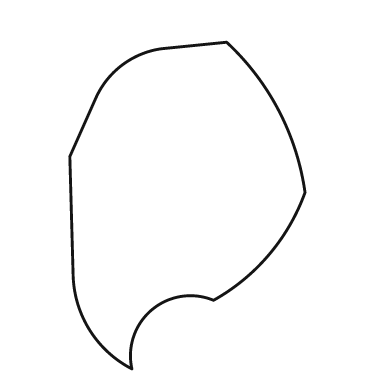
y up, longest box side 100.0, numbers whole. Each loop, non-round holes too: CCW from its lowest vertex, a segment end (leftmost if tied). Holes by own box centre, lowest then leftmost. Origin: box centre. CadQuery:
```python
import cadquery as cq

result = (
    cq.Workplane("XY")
    .moveTo(-17.0, -50.0)
    .threePointArc((-11.0, -32.0), (8.0, -29.0))
    .threePointArc((25.0, -15.0), (36.0, 4.0))
    .threePointArc((28.0, 29.0), (12.0, 50.0))
    .lineTo(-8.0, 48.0)
    .threePointArc((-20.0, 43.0), (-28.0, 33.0))
    .lineTo(-36.0, 15.0)
    .lineTo(-35.0, -21.0)
    .threePointArc((-30.0, -38.0), (-17.0, -50.0))
    .close()
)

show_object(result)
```